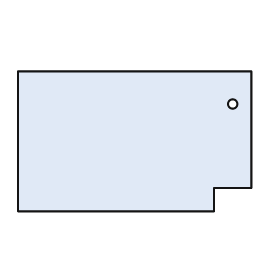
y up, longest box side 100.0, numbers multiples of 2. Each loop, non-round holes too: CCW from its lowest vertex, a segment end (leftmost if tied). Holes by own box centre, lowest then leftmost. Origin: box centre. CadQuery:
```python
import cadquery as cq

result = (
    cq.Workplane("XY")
    .moveTo(-50.0, -30.0)
    .lineTo(34.0, -30.0)
    .lineTo(34.0, -20.0)
    .lineTo(50.0, -20.0)
    .lineTo(50.0, 30.0)
    .lineTo(-50.0, 30.0)
    .close()
    .moveTo(42.0, 16.0)
    .circle(2.0)
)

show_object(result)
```